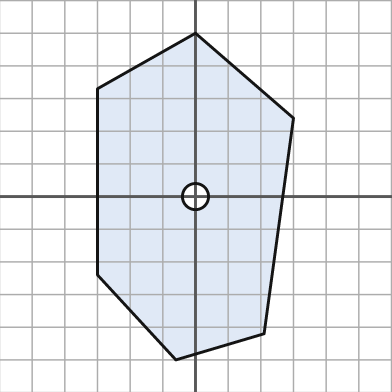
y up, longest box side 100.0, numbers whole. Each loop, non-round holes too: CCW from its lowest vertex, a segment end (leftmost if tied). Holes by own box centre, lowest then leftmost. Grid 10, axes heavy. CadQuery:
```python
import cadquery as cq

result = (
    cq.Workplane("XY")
    .moveTo(-6.0, -50.0)
    .lineTo(21.0, -42.0)
    .lineTo(30.0, 24.0)
    .lineTo(0.0, 50.0)
    .lineTo(-30.0, 33.0)
    .lineTo(-30.0, -24.0)
    .close()
    .moveTo(0.0, 0.0)
    .circle(4.0)
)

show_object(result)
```